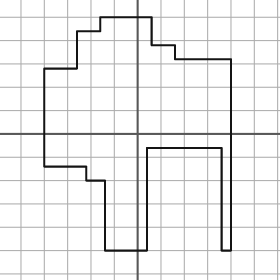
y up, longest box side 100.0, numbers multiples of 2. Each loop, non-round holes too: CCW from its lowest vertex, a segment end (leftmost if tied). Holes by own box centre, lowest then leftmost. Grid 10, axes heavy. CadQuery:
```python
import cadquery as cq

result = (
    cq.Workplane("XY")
    .moveTo(-14.0, -50.0)
    .lineTo(4.0, -50.0)
    .lineTo(4.0, -6.0)
    .lineTo(36.0, -6.0)
    .lineTo(36.0, -50.0)
    .lineTo(40.0, -50.0)
    .lineTo(40.0, 32.0)
    .lineTo(16.0, 32.0)
    .lineTo(16.0, 38.0)
    .lineTo(6.0, 38.0)
    .lineTo(6.0, 50.0)
    .lineTo(-16.0, 50.0)
    .lineTo(-16.0, 44.0)
    .lineTo(-26.0, 44.0)
    .lineTo(-26.0, 28.0)
    .lineTo(-40.0, 28.0)
    .lineTo(-40.0, -14.0)
    .lineTo(-22.0, -14.0)
    .lineTo(-22.0, -20.0)
    .lineTo(-14.0, -20.0)
    .close()
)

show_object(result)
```